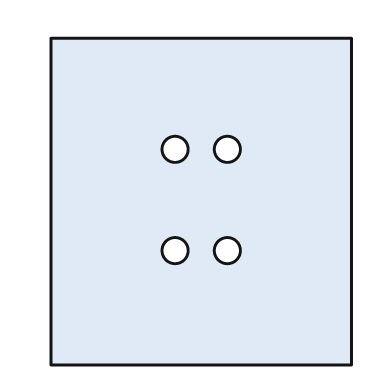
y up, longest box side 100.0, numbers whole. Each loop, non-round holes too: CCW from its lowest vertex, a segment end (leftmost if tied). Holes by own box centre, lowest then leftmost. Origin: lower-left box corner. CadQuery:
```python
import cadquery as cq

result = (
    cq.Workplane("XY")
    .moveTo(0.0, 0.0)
    .lineTo(92.0, 0.0)
    .lineTo(92.0, 100.0)
    .lineTo(0.0, 100.0)
    .close()
    .moveTo(38.0, 35.0)
    .circle(4.0)
    .moveTo(54.0, 35.0)
    .circle(4.0)
    .moveTo(38.0, 66.0)
    .circle(4.0)
    .moveTo(54.0, 66.0)
    .circle(4.0)
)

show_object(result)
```